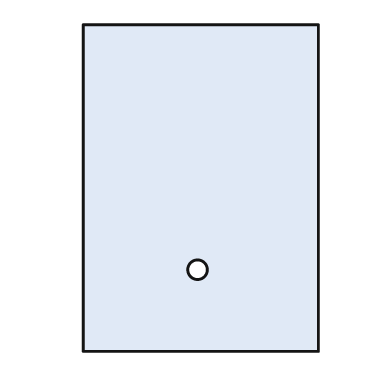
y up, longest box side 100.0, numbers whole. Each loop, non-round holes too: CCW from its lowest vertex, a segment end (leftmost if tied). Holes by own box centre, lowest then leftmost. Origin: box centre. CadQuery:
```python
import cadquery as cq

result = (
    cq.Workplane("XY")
    .moveTo(-36.0, -50.0)
    .lineTo(36.0, -50.0)
    .lineTo(36.0, 50.0)
    .lineTo(-36.0, 50.0)
    .close()
    .moveTo(-1.0, -25.0)
    .circle(3.0)
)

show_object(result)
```